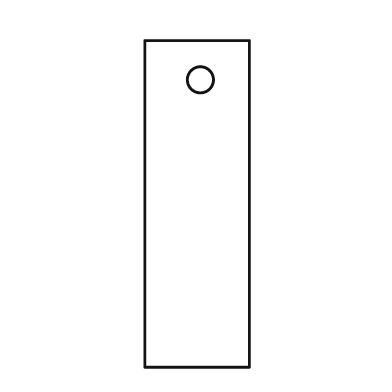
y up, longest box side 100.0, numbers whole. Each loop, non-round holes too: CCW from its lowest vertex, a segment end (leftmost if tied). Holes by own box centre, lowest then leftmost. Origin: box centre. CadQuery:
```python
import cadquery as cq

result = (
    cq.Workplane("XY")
    .moveTo(-16.0, -50.0)
    .lineTo(16.0, -50.0)
    .lineTo(16.0, 50.0)
    .lineTo(-16.0, 50.0)
    .close()
    .moveTo(1.0, 38.0)
    .circle(4.0)
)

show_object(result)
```